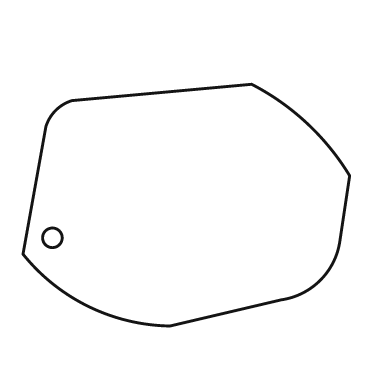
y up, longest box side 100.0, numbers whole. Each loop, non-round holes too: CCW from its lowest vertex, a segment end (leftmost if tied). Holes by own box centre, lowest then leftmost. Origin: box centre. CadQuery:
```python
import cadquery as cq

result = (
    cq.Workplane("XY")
    .moveTo(-5.0, -37.0)
    .lineTo(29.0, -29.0)
    .threePointArc((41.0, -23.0), (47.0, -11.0))
    .lineTo(50.0, 9.0)
    .threePointArc((37.0, 25.0), (20.0, 37.0))
    .lineTo(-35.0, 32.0)
    .threePointArc((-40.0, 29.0), (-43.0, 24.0))
    .lineTo(-50.0, -15.0)
    .threePointArc((-30.0, -31.0), (-5.0, -37.0))
    .close()
    .moveTo(-41.0, -10.0)
    .circle(3.0)
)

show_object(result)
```